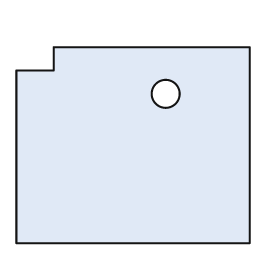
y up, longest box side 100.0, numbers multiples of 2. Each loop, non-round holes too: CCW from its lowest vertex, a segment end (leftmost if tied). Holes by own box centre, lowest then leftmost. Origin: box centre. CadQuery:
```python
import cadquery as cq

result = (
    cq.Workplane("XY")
    .moveTo(-50.0, -42.0)
    .lineTo(50.0, -42.0)
    .lineTo(50.0, 42.0)
    .lineTo(-34.0, 42.0)
    .lineTo(-34.0, 32.0)
    .lineTo(-50.0, 32.0)
    .close()
    .moveTo(14.0, 22.0)
    .circle(6.0)
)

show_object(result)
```